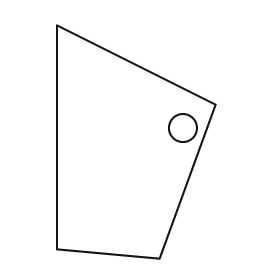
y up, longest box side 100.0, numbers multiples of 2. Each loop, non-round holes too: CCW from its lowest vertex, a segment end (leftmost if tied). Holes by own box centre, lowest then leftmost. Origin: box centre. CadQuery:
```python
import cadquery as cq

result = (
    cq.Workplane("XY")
    .moveTo(10.0, -50.0)
    .lineTo(34.0, 16.0)
    .lineTo(-34.0, 50.0)
    .lineTo(-34.0, -46.0)
    .close()
    .moveTo(20.0, 6.0)
    .circle(6.0)
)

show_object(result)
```